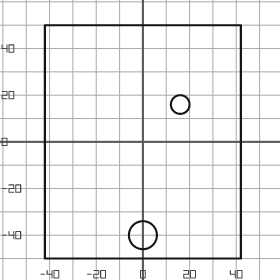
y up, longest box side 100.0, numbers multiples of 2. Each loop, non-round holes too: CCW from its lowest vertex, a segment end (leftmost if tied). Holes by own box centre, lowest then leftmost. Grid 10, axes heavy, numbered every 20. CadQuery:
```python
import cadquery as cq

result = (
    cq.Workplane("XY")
    .moveTo(-42.0, -50.0)
    .lineTo(42.0, -50.0)
    .lineTo(42.0, 50.0)
    .lineTo(-42.0, 50.0)
    .close()
    .moveTo(0.0, -40.0)
    .circle(6.0)
    .moveTo(16.0, 16.0)
    .circle(4.0)
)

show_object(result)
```